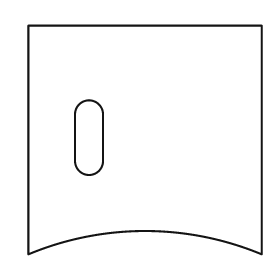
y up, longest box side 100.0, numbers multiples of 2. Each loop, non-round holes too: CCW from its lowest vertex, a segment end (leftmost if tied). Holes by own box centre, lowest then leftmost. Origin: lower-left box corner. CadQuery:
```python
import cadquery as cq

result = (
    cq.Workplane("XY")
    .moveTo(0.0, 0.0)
    .threePointArc((50.0, 10.0), (100.0, 0.0))
    .lineTo(100.0, 98.0)
    .lineTo(0.0, 98.0)
    .close()
    .moveTo(20.0, 40.0)
    .threePointArc((26.0, 34.0), (32.0, 40.0))
    .lineTo(32.0, 60.0)
    .threePointArc((26.0, 66.0), (20.0, 60.0))
    .close()
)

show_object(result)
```